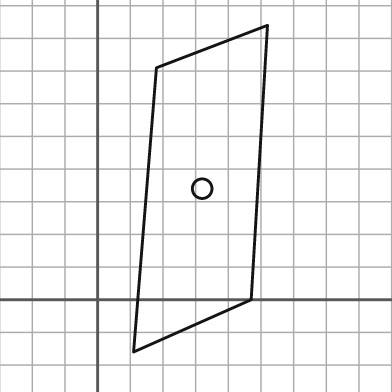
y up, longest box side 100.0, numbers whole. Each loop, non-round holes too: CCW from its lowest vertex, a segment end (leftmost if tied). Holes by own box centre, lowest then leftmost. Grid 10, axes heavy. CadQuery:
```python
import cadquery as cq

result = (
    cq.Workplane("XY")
    .moveTo(11.0, -16.0)
    .lineTo(47.0, 0.0)
    .lineTo(52.0, 84.0)
    .lineTo(18.0, 71.0)
    .close()
    .moveTo(32.0, 34.0)
    .circle(3.0)
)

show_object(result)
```